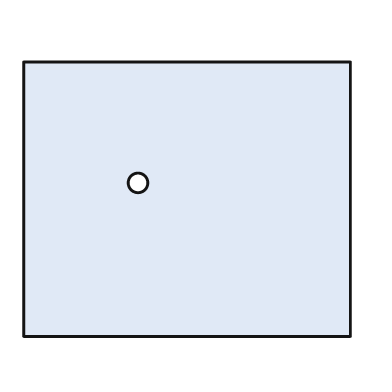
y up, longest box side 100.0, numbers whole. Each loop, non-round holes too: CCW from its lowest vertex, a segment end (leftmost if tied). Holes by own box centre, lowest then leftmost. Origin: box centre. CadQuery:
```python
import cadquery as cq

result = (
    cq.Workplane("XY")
    .moveTo(-50.0, -42.0)
    .lineTo(50.0, -42.0)
    .lineTo(50.0, 42.0)
    .lineTo(-50.0, 42.0)
    .close()
    .moveTo(-15.0, 5.0)
    .circle(3.0)
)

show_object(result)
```